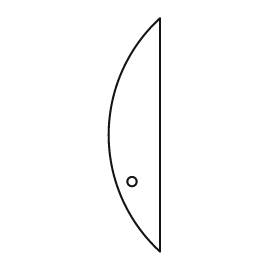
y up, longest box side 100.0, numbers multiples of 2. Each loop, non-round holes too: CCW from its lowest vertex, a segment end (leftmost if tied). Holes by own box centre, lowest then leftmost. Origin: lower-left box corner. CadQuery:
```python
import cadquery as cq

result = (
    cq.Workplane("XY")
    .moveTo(22.0, 0.0)
    .lineTo(22.0, 100.0)
    .threePointArc((0.0, 50.0), (22.0, 0.0))
    .close()
    .moveTo(10.0, 30.0)
    .circle(2.0)
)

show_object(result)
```